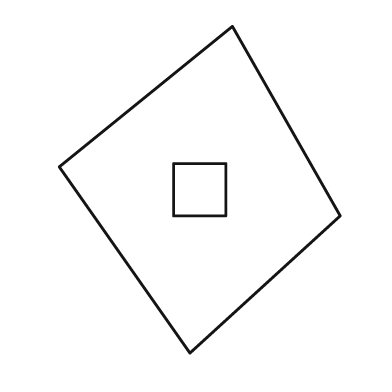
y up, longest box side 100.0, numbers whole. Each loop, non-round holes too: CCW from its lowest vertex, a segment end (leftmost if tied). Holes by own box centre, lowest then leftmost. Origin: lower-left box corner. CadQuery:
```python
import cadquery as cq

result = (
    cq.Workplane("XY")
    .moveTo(40.0, 0.0)
    .lineTo(86.0, 42.0)
    .lineTo(53.0, 100.0)
    .lineTo(0.0, 57.0)
    .close()
    .moveTo(35.0, 42.0)
    .lineTo(51.0, 42.0)
    .lineTo(51.0, 58.0)
    .lineTo(35.0, 58.0)
    .close()
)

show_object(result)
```